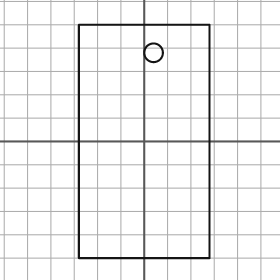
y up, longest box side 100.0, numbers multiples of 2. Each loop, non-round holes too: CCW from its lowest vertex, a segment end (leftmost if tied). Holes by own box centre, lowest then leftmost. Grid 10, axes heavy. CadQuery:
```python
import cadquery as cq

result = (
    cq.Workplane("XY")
    .moveTo(-28.0, -50.0)
    .lineTo(28.0, -50.0)
    .lineTo(28.0, 50.0)
    .lineTo(-28.0, 50.0)
    .close()
    .moveTo(4.0, 38.0)
    .circle(4.0)
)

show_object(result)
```